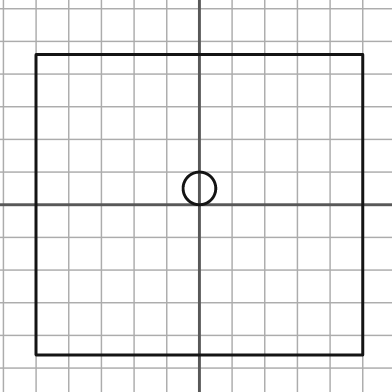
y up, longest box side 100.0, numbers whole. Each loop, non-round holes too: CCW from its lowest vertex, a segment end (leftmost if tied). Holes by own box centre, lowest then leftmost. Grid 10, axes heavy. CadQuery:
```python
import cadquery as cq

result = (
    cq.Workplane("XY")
    .moveTo(-50.0, -46.0)
    .lineTo(50.0, -46.0)
    .lineTo(50.0, 46.0)
    .lineTo(-50.0, 46.0)
    .close()
    .moveTo(0.0, 5.0)
    .circle(5.0)
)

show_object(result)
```